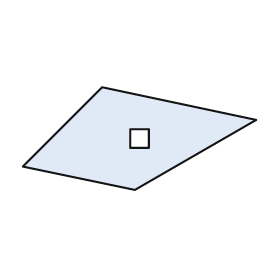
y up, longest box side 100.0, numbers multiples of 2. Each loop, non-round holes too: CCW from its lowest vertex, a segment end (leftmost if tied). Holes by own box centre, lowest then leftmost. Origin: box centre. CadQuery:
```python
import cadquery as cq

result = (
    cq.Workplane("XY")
    .moveTo(-2.0, -22.0)
    .lineTo(50.0, 8.0)
    .lineTo(-16.0, 22.0)
    .lineTo(-50.0, -12.0)
    .close()
    .moveTo(-4.0, -4.0)
    .lineTo(4.0, -4.0)
    .lineTo(4.0, 4.0)
    .lineTo(-4.0, 4.0)
    .close()
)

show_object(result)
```